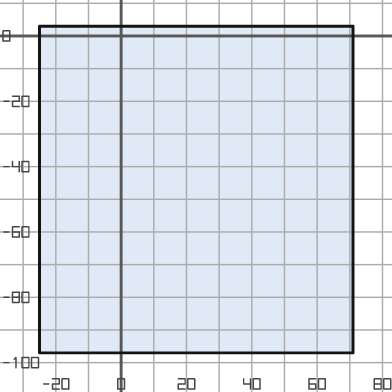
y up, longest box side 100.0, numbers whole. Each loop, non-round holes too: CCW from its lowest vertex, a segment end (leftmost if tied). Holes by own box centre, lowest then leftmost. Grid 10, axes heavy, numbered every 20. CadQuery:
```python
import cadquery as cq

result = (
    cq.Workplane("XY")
    .moveTo(-25.0, -97.0)
    .lineTo(71.0, -97.0)
    .lineTo(71.0, 3.0)
    .lineTo(-25.0, 3.0)
    .close()
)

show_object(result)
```